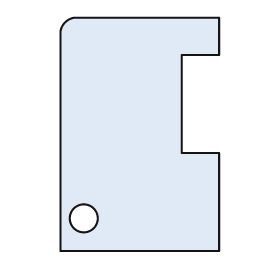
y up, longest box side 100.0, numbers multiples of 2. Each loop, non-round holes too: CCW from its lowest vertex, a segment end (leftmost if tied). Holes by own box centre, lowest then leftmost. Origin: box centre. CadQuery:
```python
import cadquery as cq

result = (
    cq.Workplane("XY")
    .moveTo(-34.0, -50.0)
    .lineTo(34.0, -50.0)
    .lineTo(34.0, -8.0)
    .lineTo(18.0, -8.0)
    .lineTo(18.0, 34.0)
    .lineTo(34.0, 34.0)
    .lineTo(34.0, 50.0)
    .lineTo(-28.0, 50.0)
    .threePointArc((-32.0, 48.0), (-34.0, 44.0))
    .close()
    .moveTo(-24.0, -36.0)
    .circle(6.0)
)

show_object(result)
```